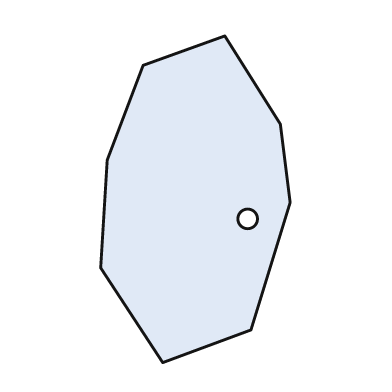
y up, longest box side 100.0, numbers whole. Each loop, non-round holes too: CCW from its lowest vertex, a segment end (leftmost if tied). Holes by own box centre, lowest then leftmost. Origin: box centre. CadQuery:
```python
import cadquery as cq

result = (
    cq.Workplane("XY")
    .moveTo(-10.0, -50.0)
    .lineTo(17.0, -40.0)
    .lineTo(29.0, -1.0)
    .lineTo(26.0, 23.0)
    .lineTo(9.0, 50.0)
    .lineTo(-16.0, 41.0)
    .lineTo(-27.0, 12.0)
    .lineTo(-29.0, -21.0)
    .close()
    .moveTo(16.0, -6.0)
    .circle(3.0)
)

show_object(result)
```